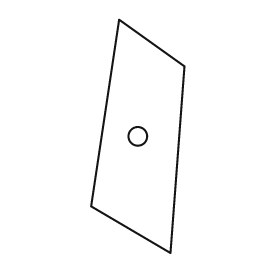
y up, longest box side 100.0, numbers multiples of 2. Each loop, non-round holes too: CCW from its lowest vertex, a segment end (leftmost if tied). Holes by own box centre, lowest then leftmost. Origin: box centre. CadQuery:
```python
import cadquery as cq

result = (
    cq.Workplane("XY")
    .moveTo(14.0, -50.0)
    .lineTo(20.0, 30.0)
    .lineTo(-8.0, 50.0)
    .lineTo(-20.0, -30.0)
    .close()
    .moveTo(0.0, 0.0)
    .circle(4.0)
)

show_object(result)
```